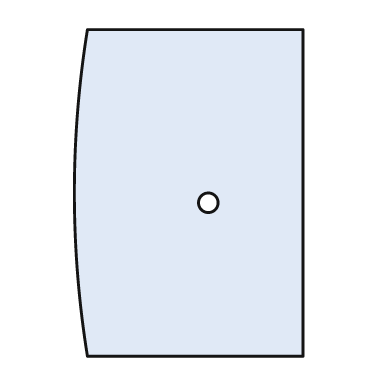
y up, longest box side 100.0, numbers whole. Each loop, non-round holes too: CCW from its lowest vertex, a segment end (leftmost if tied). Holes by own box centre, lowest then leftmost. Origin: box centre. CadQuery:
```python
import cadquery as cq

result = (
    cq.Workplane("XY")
    .moveTo(-31.0, -50.0)
    .lineTo(35.0, -50.0)
    .lineTo(35.0, 50.0)
    .lineTo(-31.0, 50.0)
    .threePointArc((-35.0, 0.0), (-31.0, -50.0))
    .close()
    .moveTo(6.0, -3.0)
    .circle(3.0)
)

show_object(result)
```